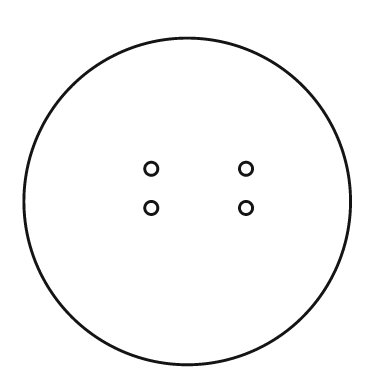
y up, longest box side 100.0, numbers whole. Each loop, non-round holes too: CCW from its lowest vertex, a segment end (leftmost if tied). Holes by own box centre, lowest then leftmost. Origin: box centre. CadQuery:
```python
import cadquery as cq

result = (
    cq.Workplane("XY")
    .moveTo(0.0, 0.0)
    .circle(50.0)
    .moveTo(-11.0, -2.0)
    .circle(2.0)
    .moveTo(18.0, -2.0)
    .circle(2.0)
    .moveTo(-11.0, 10.0)
    .circle(2.0)
    .moveTo(18.0, 10.0)
    .circle(2.0)
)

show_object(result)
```